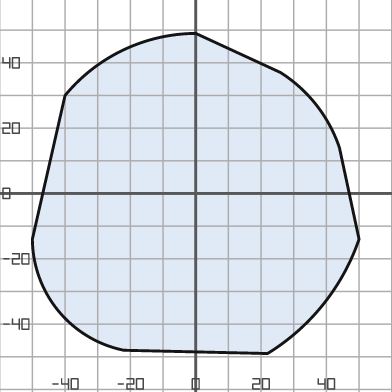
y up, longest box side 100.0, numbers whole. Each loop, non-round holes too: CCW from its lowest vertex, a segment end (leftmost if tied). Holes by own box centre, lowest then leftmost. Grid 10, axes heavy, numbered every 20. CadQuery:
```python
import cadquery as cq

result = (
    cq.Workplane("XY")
    .moveTo(22.0, -49.0)
    .threePointArc((39.0, -34.0), (50.0, -14.0))
    .lineTo(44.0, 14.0)
    .threePointArc((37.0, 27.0), (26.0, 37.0))
    .lineTo(0.0, 49.0)
    .threePointArc((-22.0, 44.0), (-40.0, 30.0))
    .lineTo(-50.0, -14.0)
    .threePointArc((-42.0, -36.0), (-22.0, -48.0))
    .close()
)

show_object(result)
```